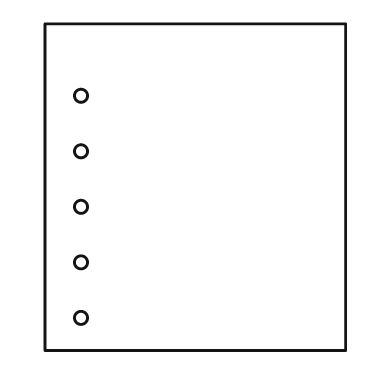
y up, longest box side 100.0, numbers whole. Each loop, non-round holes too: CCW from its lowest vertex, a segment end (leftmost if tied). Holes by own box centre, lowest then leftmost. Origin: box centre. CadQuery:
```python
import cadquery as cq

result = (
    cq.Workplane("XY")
    .moveTo(-46.0, -50.0)
    .lineTo(46.0, -50.0)
    .lineTo(46.0, 50.0)
    .lineTo(-46.0, 50.0)
    .close()
    .moveTo(-35.0, -40.0)
    .circle(2.0)
    .moveTo(-35.0, -23.0)
    .circle(2.0)
    .moveTo(-35.0, -6.0)
    .circle(2.0)
    .moveTo(-35.0, 11.0)
    .circle(2.0)
    .moveTo(-35.0, 28.0)
    .circle(2.0)
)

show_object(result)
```